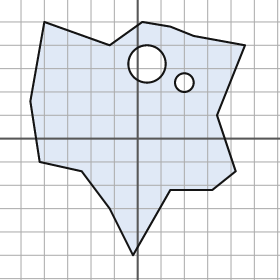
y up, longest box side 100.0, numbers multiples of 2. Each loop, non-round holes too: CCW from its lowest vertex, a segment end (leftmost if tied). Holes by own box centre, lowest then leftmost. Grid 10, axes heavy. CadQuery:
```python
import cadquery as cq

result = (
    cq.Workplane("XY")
    .moveTo(-2.0, -50.0)
    .lineTo(14.0, -22.0)
    .lineTo(32.0, -22.0)
    .lineTo(42.0, -14.0)
    .lineTo(34.0, 10.0)
    .lineTo(46.0, 40.0)
    .lineTo(24.0, 44.0)
    .lineTo(14.0, 48.0)
    .lineTo(2.0, 50.0)
    .lineTo(-12.0, 40.0)
    .lineTo(-40.0, 50.0)
    .lineTo(-46.0, 16.0)
    .lineTo(-42.0, -10.0)
    .lineTo(-24.0, -14.0)
    .lineTo(-12.0, -30.0)
    .close()
    .moveTo(20.0, 24.0)
    .circle(4.0)
    .moveTo(4.0, 32.0)
    .circle(8.0)
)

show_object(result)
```